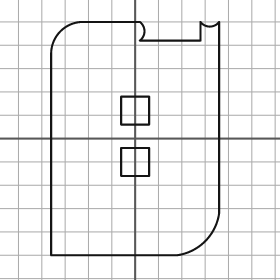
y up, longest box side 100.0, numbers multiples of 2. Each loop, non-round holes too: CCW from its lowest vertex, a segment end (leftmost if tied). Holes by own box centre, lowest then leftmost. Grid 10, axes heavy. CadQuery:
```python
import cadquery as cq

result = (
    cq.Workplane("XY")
    .moveTo(-36.0, -50.0)
    .lineTo(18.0, -50.0)
    .threePointArc((30.0, -44.0), (36.0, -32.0))
    .lineTo(36.0, 50.0)
    .threePointArc((32.0, 48.0), (28.0, 50.0))
    .lineTo(28.0, 42.0)
    .lineTo(2.0, 42.0)
    .threePointArc((4.0, 46.0), (2.0, 50.0))
    .lineTo(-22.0, 50.0)
    .threePointArc((-32.0, 46.0), (-36.0, 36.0))
    .close()
    .moveTo(-6.0, -16.0)
    .lineTo(6.0, -16.0)
    .lineTo(6.0, -4.0)
    .lineTo(-6.0, -4.0)
    .close()
    .moveTo(-6.0, 6.0)
    .lineTo(6.0, 6.0)
    .lineTo(6.0, 18.0)
    .lineTo(-6.0, 18.0)
    .close()
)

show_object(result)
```